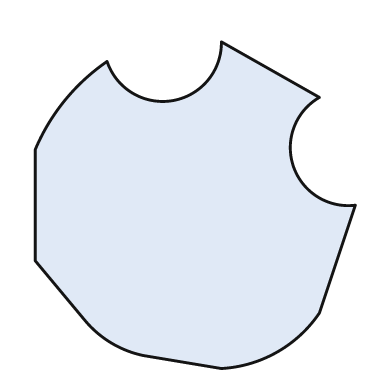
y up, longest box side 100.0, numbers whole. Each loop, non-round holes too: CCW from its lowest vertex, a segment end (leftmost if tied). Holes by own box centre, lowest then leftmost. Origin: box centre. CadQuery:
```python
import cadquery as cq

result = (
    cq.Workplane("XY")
    .moveTo(8.0, -50.0)
    .threePointArc((25.0, -45.0), (38.0, -33.0))
    .lineTo(49.0, 0.0)
    .threePointArc((30.0, 12.0), (38.0, 33.0))
    .lineTo(8.0, 50.0)
    .threePointArc((-7.0, 32.0), (-27.0, 44.0))
    .threePointArc((-40.0, 32.0), (-49.0, 17.0))
    .lineTo(-49.0, -17.0)
    .lineTo(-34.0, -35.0)
    .threePointArc((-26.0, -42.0), (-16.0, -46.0))
    .close()
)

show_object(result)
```